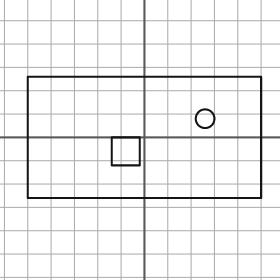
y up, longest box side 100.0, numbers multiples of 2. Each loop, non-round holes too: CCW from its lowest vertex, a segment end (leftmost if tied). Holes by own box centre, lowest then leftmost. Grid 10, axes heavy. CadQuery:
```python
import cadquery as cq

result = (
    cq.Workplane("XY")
    .moveTo(-50.0, -26.0)
    .lineTo(50.0, -26.0)
    .lineTo(50.0, 26.0)
    .lineTo(-50.0, 26.0)
    .close()
    .moveTo(-14.0, -12.0)
    .lineTo(-2.0, -12.0)
    .lineTo(-2.0, 0.0)
    .lineTo(-14.0, 0.0)
    .close()
    .moveTo(26.0, 8.0)
    .circle(4.0)
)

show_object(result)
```